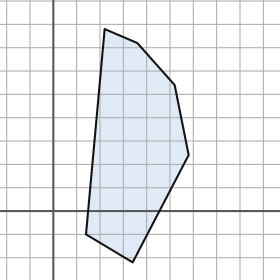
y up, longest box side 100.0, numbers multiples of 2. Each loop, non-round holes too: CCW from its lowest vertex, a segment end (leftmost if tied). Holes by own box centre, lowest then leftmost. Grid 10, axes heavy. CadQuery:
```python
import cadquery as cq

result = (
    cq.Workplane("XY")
    .moveTo(34.0, -22.0)
    .lineTo(58.0, 24.0)
    .lineTo(52.0, 54.0)
    .lineTo(36.0, 72.0)
    .lineTo(22.0, 78.0)
    .lineTo(14.0, -10.0)
    .close()
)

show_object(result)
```